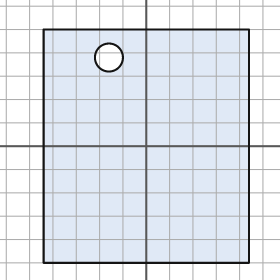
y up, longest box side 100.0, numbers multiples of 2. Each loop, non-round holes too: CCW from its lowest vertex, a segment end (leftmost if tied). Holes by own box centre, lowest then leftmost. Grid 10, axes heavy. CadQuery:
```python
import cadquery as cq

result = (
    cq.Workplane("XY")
    .moveTo(-44.0, -50.0)
    .lineTo(44.0, -50.0)
    .lineTo(44.0, 50.0)
    .lineTo(-44.0, 50.0)
    .close()
    .moveTo(-16.0, 38.0)
    .circle(6.0)
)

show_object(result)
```